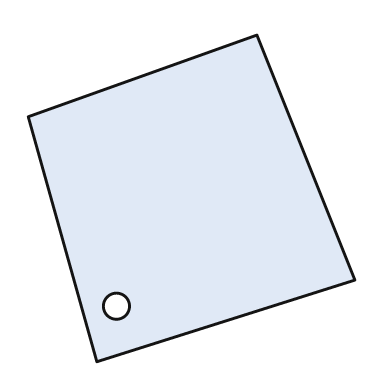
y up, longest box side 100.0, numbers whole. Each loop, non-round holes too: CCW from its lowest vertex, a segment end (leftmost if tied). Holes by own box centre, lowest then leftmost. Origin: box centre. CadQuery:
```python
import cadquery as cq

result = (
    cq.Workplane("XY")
    .moveTo(-29.0, -50.0)
    .lineTo(50.0, -25.0)
    .lineTo(20.0, 50.0)
    .lineTo(-50.0, 25.0)
    .close()
    .moveTo(-23.0, -33.0)
    .circle(4.0)
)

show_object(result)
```